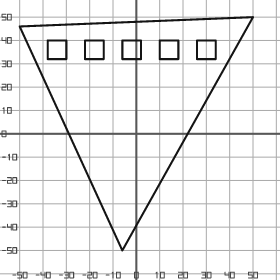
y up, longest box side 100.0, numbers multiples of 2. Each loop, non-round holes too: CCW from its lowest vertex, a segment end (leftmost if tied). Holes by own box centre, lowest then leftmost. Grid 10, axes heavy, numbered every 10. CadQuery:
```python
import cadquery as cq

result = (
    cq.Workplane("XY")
    .moveTo(-6.0, -50.0)
    .lineTo(50.0, 50.0)
    .lineTo(-50.0, 46.0)
    .close()
    .moveTo(-38.0, 32.0)
    .lineTo(-30.0, 32.0)
    .lineTo(-30.0, 40.0)
    .lineTo(-38.0, 40.0)
    .close()
    .moveTo(-22.0, 32.0)
    .lineTo(-14.0, 32.0)
    .lineTo(-14.0, 40.0)
    .lineTo(-22.0, 40.0)
    .close()
    .moveTo(-6.0, 32.0)
    .lineTo(2.0, 32.0)
    .lineTo(2.0, 40.0)
    .lineTo(-6.0, 40.0)
    .close()
    .moveTo(10.0, 32.0)
    .lineTo(18.0, 32.0)
    .lineTo(18.0, 40.0)
    .lineTo(10.0, 40.0)
    .close()
    .moveTo(26.0, 32.0)
    .lineTo(34.0, 32.0)
    .lineTo(34.0, 40.0)
    .lineTo(26.0, 40.0)
    .close()
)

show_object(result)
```